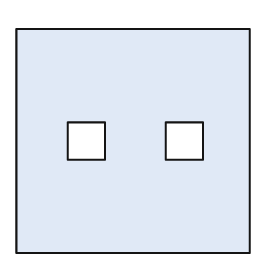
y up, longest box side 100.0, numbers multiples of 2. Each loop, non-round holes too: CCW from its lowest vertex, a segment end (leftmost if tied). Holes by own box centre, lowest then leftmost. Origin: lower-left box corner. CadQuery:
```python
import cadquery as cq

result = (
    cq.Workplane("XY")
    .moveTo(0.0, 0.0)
    .lineTo(100.0, 0.0)
    .lineTo(100.0, 96.0)
    .lineTo(0.0, 96.0)
    .close()
    .moveTo(22.0, 40.0)
    .lineTo(38.0, 40.0)
    .lineTo(38.0, 56.0)
    .lineTo(22.0, 56.0)
    .close()
    .moveTo(64.0, 40.0)
    .lineTo(80.0, 40.0)
    .lineTo(80.0, 56.0)
    .lineTo(64.0, 56.0)
    .close()
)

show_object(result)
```